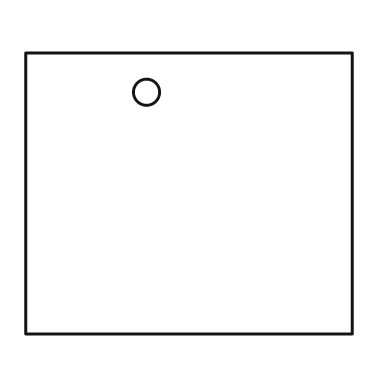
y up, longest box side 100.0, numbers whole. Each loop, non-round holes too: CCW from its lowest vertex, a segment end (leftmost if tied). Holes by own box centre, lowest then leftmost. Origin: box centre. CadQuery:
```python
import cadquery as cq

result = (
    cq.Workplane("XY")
    .moveTo(-50.0, -43.0)
    .lineTo(50.0, -43.0)
    .lineTo(50.0, 43.0)
    .lineTo(-50.0, 43.0)
    .close()
    .moveTo(-13.0, 31.0)
    .circle(4.0)
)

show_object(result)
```